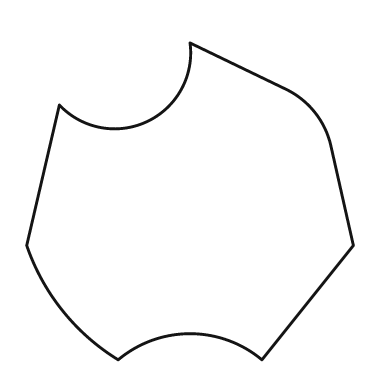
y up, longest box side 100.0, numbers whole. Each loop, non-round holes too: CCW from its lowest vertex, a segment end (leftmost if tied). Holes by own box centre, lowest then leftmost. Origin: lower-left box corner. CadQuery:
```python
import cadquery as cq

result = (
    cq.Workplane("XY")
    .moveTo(28.0, 0.0)
    .threePointArc((50.0, 8.0), (72.0, 0.0))
    .lineTo(100.0, 35.0)
    .lineTo(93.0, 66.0)
    .threePointArc((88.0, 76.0), (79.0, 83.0))
    .lineTo(50.0, 97.0)
    .threePointArc((37.0, 73.0), (10.0, 78.0))
    .lineTo(0.0, 35.0)
    .threePointArc((11.0, 15.0), (28.0, 0.0))
    .close()
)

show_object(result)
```